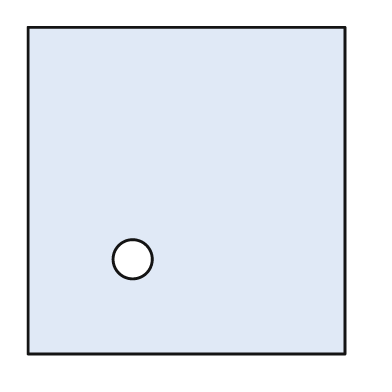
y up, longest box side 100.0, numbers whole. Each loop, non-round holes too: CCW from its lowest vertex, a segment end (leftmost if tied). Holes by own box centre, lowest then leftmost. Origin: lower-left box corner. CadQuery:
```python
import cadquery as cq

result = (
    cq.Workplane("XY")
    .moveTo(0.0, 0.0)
    .lineTo(97.0, 0.0)
    .lineTo(97.0, 100.0)
    .lineTo(0.0, 100.0)
    .close()
    .moveTo(32.0, 29.0)
    .circle(6.0)
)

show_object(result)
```